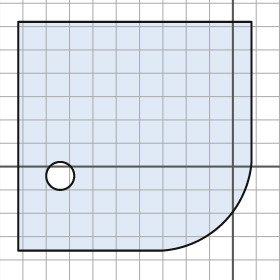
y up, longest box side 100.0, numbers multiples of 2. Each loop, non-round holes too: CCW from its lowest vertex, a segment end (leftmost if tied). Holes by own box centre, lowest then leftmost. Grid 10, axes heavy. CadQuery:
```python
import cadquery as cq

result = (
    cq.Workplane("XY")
    .moveTo(-92.0, -36.0)
    .lineTo(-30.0, -36.0)
    .threePointArc((-4.0, -24.0), (8.0, 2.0))
    .lineTo(8.0, 62.0)
    .lineTo(-92.0, 62.0)
    .close()
    .moveTo(-74.0, -4.0)
    .circle(6.0)
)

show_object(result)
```